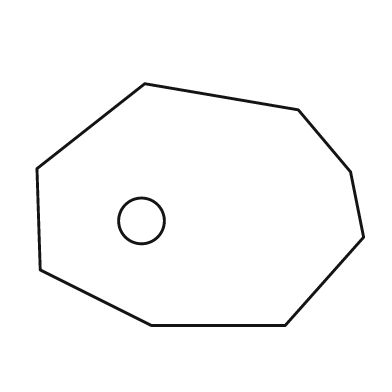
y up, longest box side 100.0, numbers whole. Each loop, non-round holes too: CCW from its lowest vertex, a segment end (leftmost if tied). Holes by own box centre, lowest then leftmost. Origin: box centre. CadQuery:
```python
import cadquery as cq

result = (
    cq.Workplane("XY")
    .moveTo(-15.0, -37.0)
    .lineTo(26.0, -37.0)
    .lineTo(50.0, -10.0)
    .lineTo(46.0, 10.0)
    .lineTo(30.0, 29.0)
    .lineTo(-17.0, 37.0)
    .lineTo(-50.0, 11.0)
    .lineTo(-49.0, -20.0)
    .close()
    .moveTo(-18.0, -5.0)
    .circle(7.0)
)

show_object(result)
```